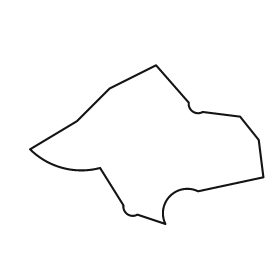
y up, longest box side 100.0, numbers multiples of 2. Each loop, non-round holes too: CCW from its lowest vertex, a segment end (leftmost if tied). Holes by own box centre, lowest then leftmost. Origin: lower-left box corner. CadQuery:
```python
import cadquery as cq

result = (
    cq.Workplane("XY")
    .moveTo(58.0, 0.0)
    .threePointArc((60.0, 12.0), (72.0, 14.0))
    .lineTo(100.0, 20.0)
    .lineTo(98.0, 36.0)
    .lineTo(90.0, 46.0)
    .lineTo(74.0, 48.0)
    .threePointArc((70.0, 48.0), (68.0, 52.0))
    .lineTo(54.0, 68.0)
    .lineTo(34.0, 58.0)
    .lineTo(20.0, 44.0)
    .lineTo(0.0, 32.0)
    .threePointArc((14.0, 24.0), (30.0, 24.0))
    .lineTo(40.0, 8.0)
    .threePointArc((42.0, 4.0), (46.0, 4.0))
    .close()
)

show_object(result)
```